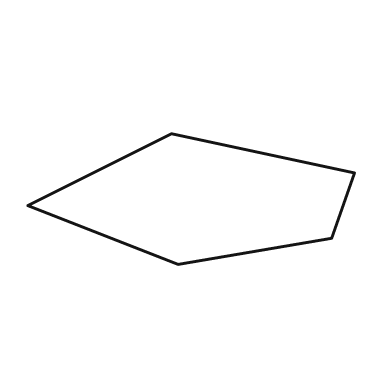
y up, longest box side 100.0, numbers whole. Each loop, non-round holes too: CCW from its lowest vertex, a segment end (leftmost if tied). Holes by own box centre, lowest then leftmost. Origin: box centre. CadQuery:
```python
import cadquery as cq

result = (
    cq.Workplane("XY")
    .moveTo(-4.0, -20.0)
    .lineTo(43.0, -12.0)
    .lineTo(50.0, 8.0)
    .lineTo(-6.0, 20.0)
    .lineTo(-50.0, -2.0)
    .close()
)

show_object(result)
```